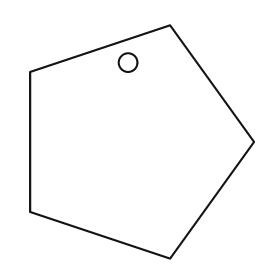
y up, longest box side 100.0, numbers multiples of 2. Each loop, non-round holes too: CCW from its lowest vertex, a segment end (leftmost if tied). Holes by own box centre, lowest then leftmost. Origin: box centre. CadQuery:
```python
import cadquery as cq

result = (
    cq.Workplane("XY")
    .moveTo(12.0, -50.0)
    .lineTo(48.0, 0.0)
    .lineTo(12.0, 50.0)
    .lineTo(-48.0, 30.0)
    .lineTo(-48.0, -30.0)
    .close()
    .moveTo(-6.0, 34.0)
    .circle(4.0)
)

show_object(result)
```